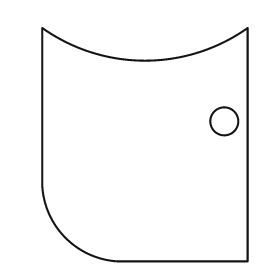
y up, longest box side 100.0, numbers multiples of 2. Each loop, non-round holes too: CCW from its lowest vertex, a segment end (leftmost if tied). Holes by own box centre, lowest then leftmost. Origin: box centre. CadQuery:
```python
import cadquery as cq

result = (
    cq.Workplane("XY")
    .moveTo(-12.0, -50.0)
    .lineTo(44.0, -50.0)
    .lineTo(44.0, 50.0)
    .threePointArc((0.0, 36.0), (-44.0, 50.0))
    .lineTo(-44.0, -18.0)
    .threePointArc((-34.0, -40.0), (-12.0, -50.0))
    .close()
    .moveTo(34.0, 10.0)
    .circle(6.0)
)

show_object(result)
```